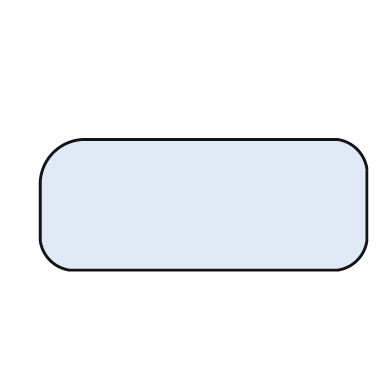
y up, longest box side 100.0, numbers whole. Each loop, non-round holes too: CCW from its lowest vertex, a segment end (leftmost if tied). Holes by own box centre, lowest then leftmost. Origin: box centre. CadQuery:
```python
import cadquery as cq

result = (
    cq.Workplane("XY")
    .moveTo(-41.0, -20.0)
    .lineTo(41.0, -20.0)
    .threePointArc((47.0, -17.0), (50.0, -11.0))
    .lineTo(50.0, 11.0)
    .threePointArc((47.0, 17.0), (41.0, 20.0))
    .lineTo(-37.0, 20.0)
    .threePointArc((-46.0, 16.0), (-50.0, 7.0))
    .lineTo(-50.0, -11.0)
    .threePointArc((-47.0, -17.0), (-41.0, -20.0))
    .close()
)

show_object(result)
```